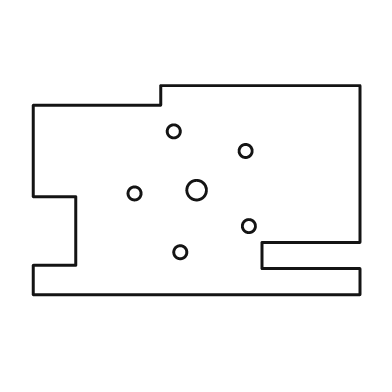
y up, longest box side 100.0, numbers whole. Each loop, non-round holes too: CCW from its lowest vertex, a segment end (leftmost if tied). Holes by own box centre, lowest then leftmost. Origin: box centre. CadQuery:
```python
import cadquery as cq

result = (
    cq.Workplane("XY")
    .moveTo(-50.0, -32.0)
    .lineTo(50.0, -32.0)
    .lineTo(50.0, -24.0)
    .lineTo(20.0, -24.0)
    .lineTo(20.0, -16.0)
    .lineTo(50.0, -16.0)
    .lineTo(50.0, 32.0)
    .lineTo(-11.0, 32.0)
    .lineTo(-11.0, 26.0)
    .lineTo(-50.0, 26.0)
    .lineTo(-50.0, -2.0)
    .lineTo(-37.0, -2.0)
    .lineTo(-37.0, -23.0)
    .lineTo(-50.0, -23.0)
    .close()
    .moveTo(-5.0, -19.0)
    .circle(2.0)
    .moveTo(16.0, -11.0)
    .circle(2.0)
    .moveTo(-19.0, -1.0)
    .circle(2.0)
    .moveTo(0.0, 0.0)
    .circle(3.0)
    .moveTo(15.0, 12.0)
    .circle(2.0)
    .moveTo(-7.0, 18.0)
    .circle(2.0)
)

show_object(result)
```